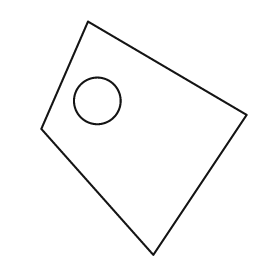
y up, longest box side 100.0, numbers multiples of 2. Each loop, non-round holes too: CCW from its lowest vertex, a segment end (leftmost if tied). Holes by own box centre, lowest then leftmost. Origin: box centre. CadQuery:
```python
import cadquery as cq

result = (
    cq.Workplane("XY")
    .moveTo(4.0, -50.0)
    .lineTo(44.0, 10.0)
    .lineTo(-24.0, 50.0)
    .lineTo(-44.0, 4.0)
    .close()
    .moveTo(-20.0, 16.0)
    .circle(10.0)
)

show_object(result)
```